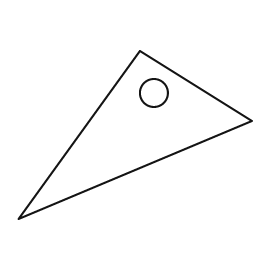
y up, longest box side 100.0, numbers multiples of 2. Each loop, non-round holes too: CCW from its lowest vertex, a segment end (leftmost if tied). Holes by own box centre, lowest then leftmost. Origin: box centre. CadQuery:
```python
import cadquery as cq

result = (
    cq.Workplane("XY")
    .moveTo(-50.0, -36.0)
    .lineTo(50.0, 6.0)
    .lineTo(2.0, 36.0)
    .close()
    .moveTo(8.0, 18.0)
    .circle(6.0)
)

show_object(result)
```